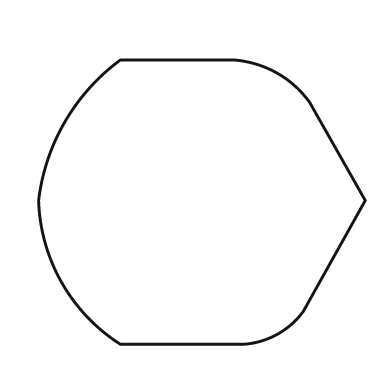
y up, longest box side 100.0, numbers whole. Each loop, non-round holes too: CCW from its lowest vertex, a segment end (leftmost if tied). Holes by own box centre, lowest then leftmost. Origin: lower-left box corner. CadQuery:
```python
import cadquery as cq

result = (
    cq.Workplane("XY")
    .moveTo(25.0, 0.0)
    .lineTo(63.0, 0.0)
    .threePointArc((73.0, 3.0), (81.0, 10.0))
    .lineTo(100.0, 44.0)
    .lineTo(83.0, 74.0)
    .threePointArc((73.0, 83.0), (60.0, 87.0))
    .lineTo(25.0, 87.0)
    .threePointArc((8.0, 68.0), (0.0, 44.0))
    .threePointArc((7.0, 19.0), (25.0, 0.0))
    .close()
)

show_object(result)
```